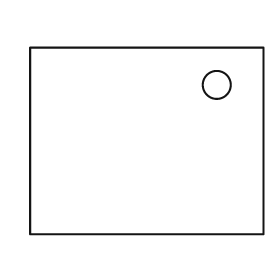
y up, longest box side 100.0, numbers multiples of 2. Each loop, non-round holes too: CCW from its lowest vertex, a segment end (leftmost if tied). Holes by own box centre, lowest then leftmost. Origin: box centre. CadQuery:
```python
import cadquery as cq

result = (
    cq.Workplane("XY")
    .moveTo(-50.0, -40.0)
    .lineTo(50.0, -40.0)
    .lineTo(50.0, 40.0)
    .lineTo(-50.0, 40.0)
    .close()
    .moveTo(30.0, 24.0)
    .circle(6.0)
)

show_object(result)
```